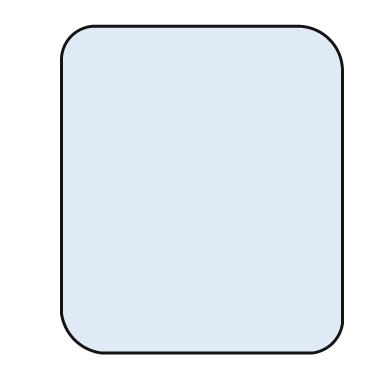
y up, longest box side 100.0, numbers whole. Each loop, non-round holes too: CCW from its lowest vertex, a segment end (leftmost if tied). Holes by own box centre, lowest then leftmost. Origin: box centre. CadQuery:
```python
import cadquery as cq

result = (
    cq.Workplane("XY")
    .moveTo(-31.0, -50.0)
    .lineTo(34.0, -50.0)
    .threePointArc((40.0, -47.0), (43.0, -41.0))
    .lineTo(43.0, 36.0)
    .threePointArc((39.0, 46.0), (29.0, 50.0))
    .lineTo(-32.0, 50.0)
    .threePointArc((-40.0, 47.0), (-43.0, 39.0))
    .lineTo(-43.0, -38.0)
    .threePointArc((-39.0, -46.0), (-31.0, -50.0))
    .close()
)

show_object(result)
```